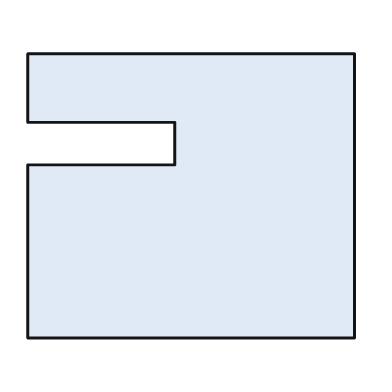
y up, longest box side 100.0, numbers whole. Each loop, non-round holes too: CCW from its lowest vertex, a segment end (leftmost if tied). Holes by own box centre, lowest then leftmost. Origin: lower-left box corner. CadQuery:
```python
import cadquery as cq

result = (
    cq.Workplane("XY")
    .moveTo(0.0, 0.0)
    .lineTo(100.0, 0.0)
    .lineTo(100.0, 87.0)
    .lineTo(0.0, 87.0)
    .lineTo(0.0, 66.0)
    .lineTo(45.0, 66.0)
    .lineTo(45.0, 53.0)
    .lineTo(0.0, 53.0)
    .close()
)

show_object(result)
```